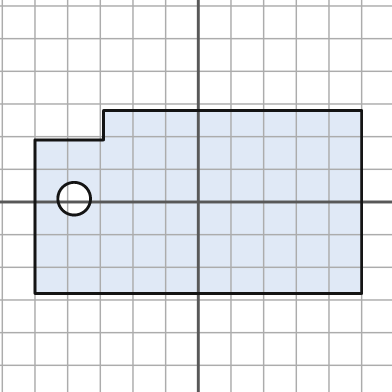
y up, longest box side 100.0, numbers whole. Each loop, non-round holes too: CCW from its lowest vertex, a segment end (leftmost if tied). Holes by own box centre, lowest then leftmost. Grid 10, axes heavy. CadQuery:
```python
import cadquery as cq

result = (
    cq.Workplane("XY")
    .moveTo(-50.0, -28.0)
    .lineTo(50.0, -28.0)
    .lineTo(50.0, 28.0)
    .lineTo(-29.0, 28.0)
    .lineTo(-29.0, 19.0)
    .lineTo(-50.0, 19.0)
    .close()
    .moveTo(-38.0, 1.0)
    .circle(5.0)
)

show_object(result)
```